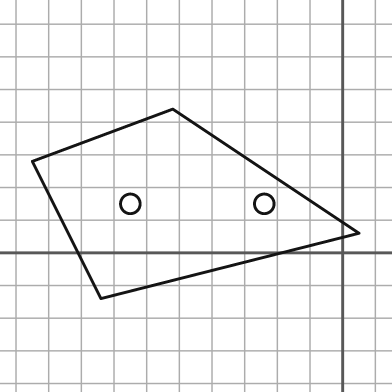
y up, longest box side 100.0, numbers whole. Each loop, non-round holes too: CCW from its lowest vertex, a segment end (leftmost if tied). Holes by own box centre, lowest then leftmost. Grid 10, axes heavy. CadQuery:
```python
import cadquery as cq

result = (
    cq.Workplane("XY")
    .moveTo(-74.0, -14.0)
    .lineTo(5.0, 6.0)
    .lineTo(-52.0, 44.0)
    .lineTo(-95.0, 28.0)
    .close()
    .moveTo(-65.0, 15.0)
    .circle(3.0)
    .moveTo(-24.0, 15.0)
    .circle(3.0)
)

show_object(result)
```